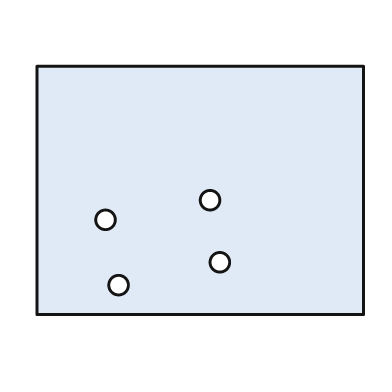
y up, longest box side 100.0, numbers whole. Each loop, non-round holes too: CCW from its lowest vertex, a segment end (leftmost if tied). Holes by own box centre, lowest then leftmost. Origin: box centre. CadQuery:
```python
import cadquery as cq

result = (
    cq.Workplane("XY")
    .moveTo(-50.0, -38.0)
    .lineTo(50.0, -38.0)
    .lineTo(50.0, 38.0)
    .lineTo(-50.0, 38.0)
    .close()
    .moveTo(-25.0, -29.0)
    .circle(3.0)
    .moveTo(6.0, -22.0)
    .circle(3.0)
    .moveTo(-29.0, -9.0)
    .circle(3.0)
    .moveTo(3.0, -3.0)
    .circle(3.0)
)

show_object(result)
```